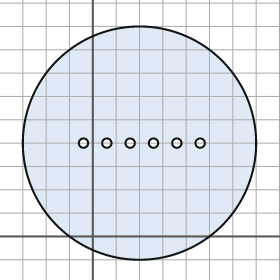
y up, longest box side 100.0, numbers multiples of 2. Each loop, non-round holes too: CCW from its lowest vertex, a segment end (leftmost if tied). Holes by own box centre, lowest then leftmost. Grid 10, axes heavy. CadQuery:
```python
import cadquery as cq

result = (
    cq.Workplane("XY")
    .moveTo(20.0, 40.0)
    .circle(50.0)
    .moveTo(-4.0, 40.0)
    .circle(2.0)
    .moveTo(6.0, 40.0)
    .circle(2.0)
    .moveTo(16.0, 40.0)
    .circle(2.0)
    .moveTo(26.0, 40.0)
    .circle(2.0)
    .moveTo(36.0, 40.0)
    .circle(2.0)
    .moveTo(46.0, 40.0)
    .circle(2.0)
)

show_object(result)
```